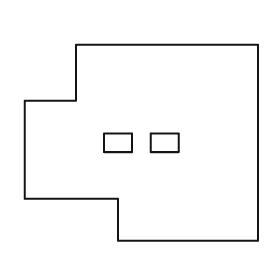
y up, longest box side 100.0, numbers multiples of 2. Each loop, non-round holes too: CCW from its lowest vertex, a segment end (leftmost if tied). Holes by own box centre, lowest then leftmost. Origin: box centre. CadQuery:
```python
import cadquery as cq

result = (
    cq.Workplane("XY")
    .moveTo(-10.0, -42.0)
    .lineTo(50.0, -42.0)
    .lineTo(50.0, 42.0)
    .lineTo(-28.0, 42.0)
    .lineTo(-28.0, 18.0)
    .lineTo(-50.0, 18.0)
    .lineTo(-50.0, -24.0)
    .lineTo(-10.0, -24.0)
    .close()
    .moveTo(-16.0, -4.0)
    .lineTo(-4.0, -4.0)
    .lineTo(-4.0, 4.0)
    .lineTo(-16.0, 4.0)
    .close()
    .moveTo(4.0, -4.0)
    .lineTo(16.0, -4.0)
    .lineTo(16.0, 4.0)
    .lineTo(4.0, 4.0)
    .close()
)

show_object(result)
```